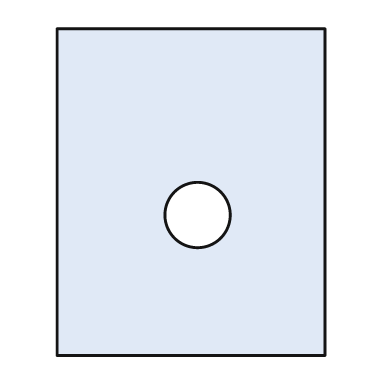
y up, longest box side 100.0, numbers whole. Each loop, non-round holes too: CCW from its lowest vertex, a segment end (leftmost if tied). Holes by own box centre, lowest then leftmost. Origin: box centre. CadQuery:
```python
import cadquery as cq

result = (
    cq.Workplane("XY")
    .moveTo(-41.0, -50.0)
    .lineTo(41.0, -50.0)
    .lineTo(41.0, 50.0)
    .lineTo(-41.0, 50.0)
    .close()
    .moveTo(2.0, -7.0)
    .circle(10.0)
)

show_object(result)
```